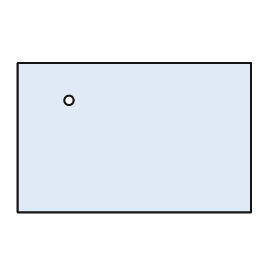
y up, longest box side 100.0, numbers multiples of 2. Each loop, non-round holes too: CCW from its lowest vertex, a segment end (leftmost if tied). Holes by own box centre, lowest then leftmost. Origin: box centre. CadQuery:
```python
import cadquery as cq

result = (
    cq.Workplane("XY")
    .moveTo(-50.0, -32.0)
    .lineTo(50.0, -32.0)
    .lineTo(50.0, 32.0)
    .lineTo(-50.0, 32.0)
    .close()
    .moveTo(-28.0, 16.0)
    .circle(2.0)
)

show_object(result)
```